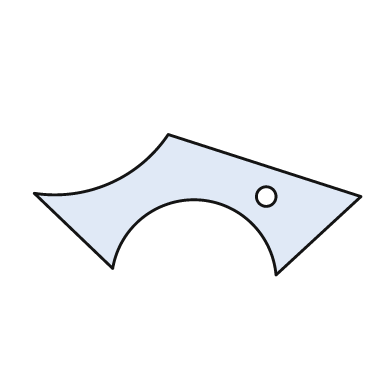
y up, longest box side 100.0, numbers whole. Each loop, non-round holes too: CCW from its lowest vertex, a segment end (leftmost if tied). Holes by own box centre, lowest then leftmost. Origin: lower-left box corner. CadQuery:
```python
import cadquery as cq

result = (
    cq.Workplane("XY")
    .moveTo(74.0, 0.0)
    .lineTo(100.0, 24.0)
    .lineTo(41.0, 43.0)
    .threePointArc((23.0, 28.0), (0.0, 25.0))
    .lineTo(24.0, 2.0)
    .threePointArc((50.0, 23.0), (74.0, 0.0))
    .close()
    .moveTo(71.0, 24.0)
    .circle(3.0)
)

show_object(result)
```